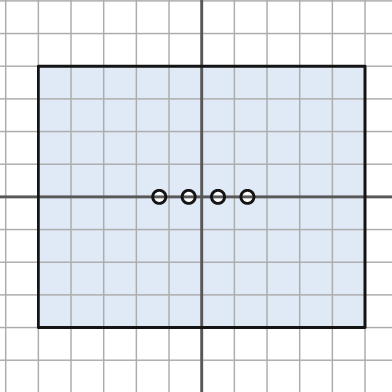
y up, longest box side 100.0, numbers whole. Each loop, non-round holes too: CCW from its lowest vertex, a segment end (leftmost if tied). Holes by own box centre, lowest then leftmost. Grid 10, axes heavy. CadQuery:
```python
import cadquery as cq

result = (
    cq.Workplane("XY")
    .moveTo(-50.0, -40.0)
    .lineTo(50.0, -40.0)
    .lineTo(50.0, 40.0)
    .lineTo(-50.0, 40.0)
    .close()
    .moveTo(-13.0, 0.0)
    .circle(2.0)
    .moveTo(-4.0, 0.0)
    .circle(2.0)
    .moveTo(5.0, 0.0)
    .circle(2.0)
    .moveTo(14.0, 0.0)
    .circle(2.0)
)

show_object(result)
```